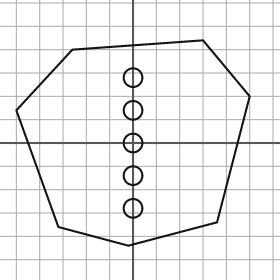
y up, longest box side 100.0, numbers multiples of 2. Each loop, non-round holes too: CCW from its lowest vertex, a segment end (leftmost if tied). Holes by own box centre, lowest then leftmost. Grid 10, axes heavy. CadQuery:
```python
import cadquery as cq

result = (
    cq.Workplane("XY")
    .moveTo(-2.0, -44.0)
    .lineTo(36.0, -34.0)
    .lineTo(50.0, 20.0)
    .lineTo(30.0, 44.0)
    .lineTo(-26.0, 40.0)
    .lineTo(-50.0, 14.0)
    .lineTo(-32.0, -36.0)
    .close()
    .moveTo(0.0, -28.0)
    .circle(4.0)
    .moveTo(0.0, -14.0)
    .circle(4.0)
    .moveTo(0.0, 0.0)
    .circle(4.0)
    .moveTo(0.0, 14.0)
    .circle(4.0)
    .moveTo(0.0, 28.0)
    .circle(4.0)
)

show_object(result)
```